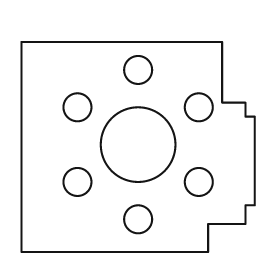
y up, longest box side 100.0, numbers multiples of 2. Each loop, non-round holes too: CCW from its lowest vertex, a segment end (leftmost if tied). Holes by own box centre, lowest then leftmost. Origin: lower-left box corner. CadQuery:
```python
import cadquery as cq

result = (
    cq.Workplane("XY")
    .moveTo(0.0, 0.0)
    .lineTo(80.0, 0.0)
    .lineTo(80.0, 12.0)
    .lineTo(96.0, 12.0)
    .lineTo(96.0, 20.0)
    .lineTo(100.0, 20.0)
    .lineTo(100.0, 58.0)
    .lineTo(96.0, 58.0)
    .lineTo(96.0, 64.0)
    .lineTo(86.0, 64.0)
    .lineTo(86.0, 90.0)
    .lineTo(0.0, 90.0)
    .close()
    .moveTo(50.0, 14.0)
    .circle(6.0)
    .moveTo(24.0, 30.0)
    .circle(6.0)
    .moveTo(76.0, 30.0)
    .circle(6.0)
    .moveTo(50.0, 46.0)
    .circle(16.0)
    .moveTo(24.0, 62.0)
    .circle(6.0)
    .moveTo(76.0, 62.0)
    .circle(6.0)
    .moveTo(50.0, 78.0)
    .circle(6.0)
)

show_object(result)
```